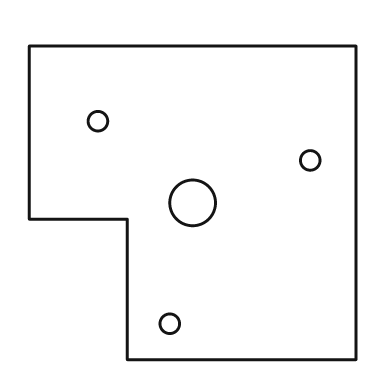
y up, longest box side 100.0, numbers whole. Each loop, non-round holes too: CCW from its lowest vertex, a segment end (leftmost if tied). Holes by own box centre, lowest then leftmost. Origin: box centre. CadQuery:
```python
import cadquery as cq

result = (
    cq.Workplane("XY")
    .moveTo(-20.0, -48.0)
    .lineTo(50.0, -48.0)
    .lineTo(50.0, 48.0)
    .lineTo(-50.0, 48.0)
    .lineTo(-50.0, -5.0)
    .lineTo(-20.0, -5.0)
    .close()
    .moveTo(-7.0, -37.0)
    .circle(3.0)
    .moveTo(0.0, 0.0)
    .circle(7.0)
    .moveTo(36.0, 13.0)
    .circle(3.0)
    .moveTo(-29.0, 25.0)
    .circle(3.0)
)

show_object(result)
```